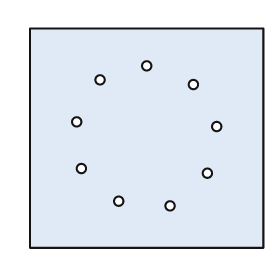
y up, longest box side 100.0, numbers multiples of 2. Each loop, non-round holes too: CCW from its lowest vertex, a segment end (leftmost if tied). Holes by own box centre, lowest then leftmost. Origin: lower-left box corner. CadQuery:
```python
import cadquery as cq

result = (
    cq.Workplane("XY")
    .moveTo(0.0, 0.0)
    .lineTo(100.0, 0.0)
    .lineTo(100.0, 94.0)
    .lineTo(0.0, 94.0)
    .close()
    .moveTo(60.0, 18.0)
    .circle(2.0)
    .moveTo(38.0, 20.0)
    .circle(2.0)
    .moveTo(76.0, 32.0)
    .circle(2.0)
    .moveTo(22.0, 34.0)
    .circle(2.0)
    .moveTo(80.0, 52.0)
    .circle(2.0)
    .moveTo(20.0, 54.0)
    .circle(2.0)
    .moveTo(70.0, 70.0)
    .circle(2.0)
    .moveTo(30.0, 72.0)
    .circle(2.0)
    .moveTo(50.0, 78.0)
    .circle(2.0)
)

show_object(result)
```